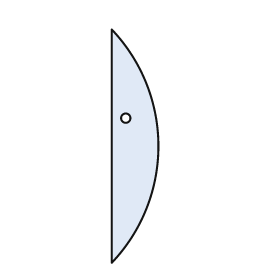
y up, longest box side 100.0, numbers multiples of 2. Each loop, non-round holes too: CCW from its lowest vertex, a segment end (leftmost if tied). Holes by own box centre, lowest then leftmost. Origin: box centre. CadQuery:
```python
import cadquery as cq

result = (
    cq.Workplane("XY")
    .moveTo(-10.0, -50.0)
    .threePointArc((10.0, 0.0), (-10.0, 50.0))
    .close()
    .moveTo(-4.0, 12.0)
    .circle(2.0)
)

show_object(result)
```